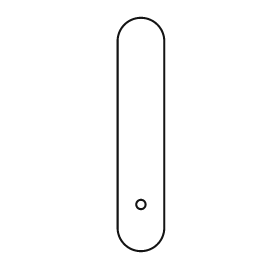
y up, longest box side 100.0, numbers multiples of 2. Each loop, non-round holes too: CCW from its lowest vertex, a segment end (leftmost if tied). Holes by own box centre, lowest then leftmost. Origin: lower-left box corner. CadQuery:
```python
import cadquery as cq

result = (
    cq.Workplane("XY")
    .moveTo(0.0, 10.0)
    .threePointArc((10.0, 0.0), (20.0, 10.0))
    .lineTo(20.0, 90.0)
    .threePointArc((10.0, 100.0), (0.0, 90.0))
    .close()
    .moveTo(10.0, 20.0)
    .circle(2.0)
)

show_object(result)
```